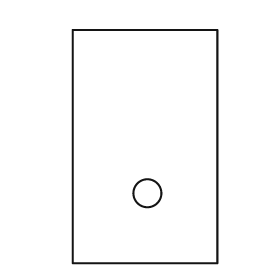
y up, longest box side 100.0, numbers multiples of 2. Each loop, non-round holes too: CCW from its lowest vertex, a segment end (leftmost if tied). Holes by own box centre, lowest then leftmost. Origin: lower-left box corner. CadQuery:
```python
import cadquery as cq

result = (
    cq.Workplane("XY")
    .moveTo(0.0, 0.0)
    .lineTo(62.0, 0.0)
    .lineTo(62.0, 100.0)
    .lineTo(0.0, 100.0)
    .close()
    .moveTo(32.0, 30.0)
    .circle(6.0)
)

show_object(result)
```